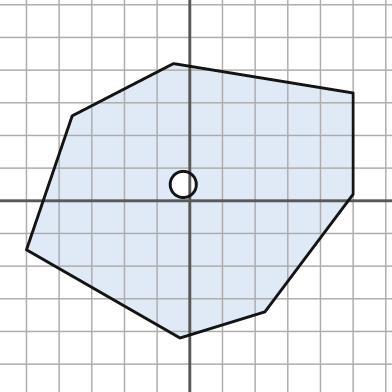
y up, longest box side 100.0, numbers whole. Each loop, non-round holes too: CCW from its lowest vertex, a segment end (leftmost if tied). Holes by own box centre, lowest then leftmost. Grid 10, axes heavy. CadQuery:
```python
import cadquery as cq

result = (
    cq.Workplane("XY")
    .moveTo(-3.0, -42.0)
    .lineTo(23.0, -34.0)
    .lineTo(50.0, 2.0)
    .lineTo(50.0, 33.0)
    .lineTo(-5.0, 42.0)
    .lineTo(-36.0, 26.0)
    .lineTo(-50.0, -15.0)
    .close()
    .moveTo(-2.0, 5.0)
    .circle(4.0)
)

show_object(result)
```